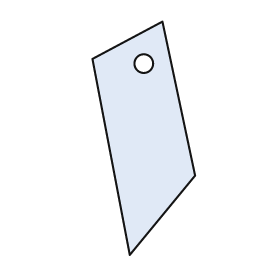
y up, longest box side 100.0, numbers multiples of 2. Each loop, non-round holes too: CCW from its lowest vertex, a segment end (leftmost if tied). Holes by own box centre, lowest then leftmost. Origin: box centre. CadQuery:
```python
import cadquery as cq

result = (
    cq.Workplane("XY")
    .moveTo(-6.0, -50.0)
    .lineTo(22.0, -16.0)
    .lineTo(8.0, 50.0)
    .lineTo(-22.0, 34.0)
    .close()
    .moveTo(0.0, 32.0)
    .circle(4.0)
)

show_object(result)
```